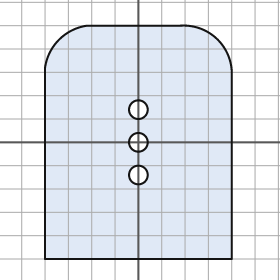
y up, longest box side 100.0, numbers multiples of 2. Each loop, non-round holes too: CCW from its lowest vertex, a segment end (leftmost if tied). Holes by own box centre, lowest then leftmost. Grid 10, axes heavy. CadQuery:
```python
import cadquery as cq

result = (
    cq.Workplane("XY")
    .moveTo(-40.0, -50.0)
    .lineTo(40.0, -50.0)
    .lineTo(40.0, 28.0)
    .threePointArc((34.0, 44.0), (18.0, 50.0))
    .lineTo(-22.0, 50.0)
    .threePointArc((-34.0, 44.0), (-40.0, 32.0))
    .close()
    .moveTo(0.0, -14.0)
    .circle(4.0)
    .moveTo(0.0, 0.0)
    .circle(4.0)
    .moveTo(0.0, 14.0)
    .circle(4.0)
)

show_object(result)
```